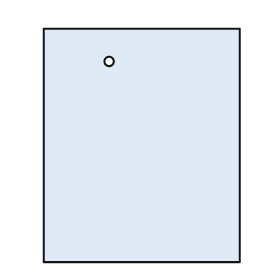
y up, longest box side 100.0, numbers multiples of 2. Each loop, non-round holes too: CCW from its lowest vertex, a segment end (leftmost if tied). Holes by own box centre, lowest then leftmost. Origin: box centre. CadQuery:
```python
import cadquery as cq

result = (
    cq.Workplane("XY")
    .moveTo(-42.0, -50.0)
    .lineTo(42.0, -50.0)
    .lineTo(42.0, 50.0)
    .lineTo(-42.0, 50.0)
    .close()
    .moveTo(-14.0, 36.0)
    .circle(2.0)
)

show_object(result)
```